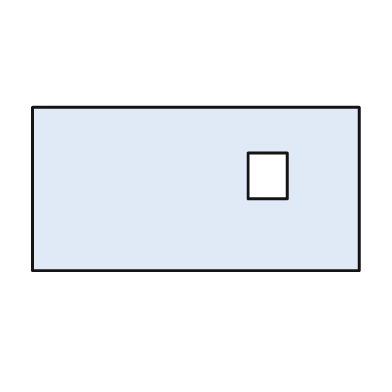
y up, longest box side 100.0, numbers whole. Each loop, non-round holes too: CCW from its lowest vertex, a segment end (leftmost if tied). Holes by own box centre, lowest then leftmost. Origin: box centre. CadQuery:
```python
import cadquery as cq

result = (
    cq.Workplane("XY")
    .moveTo(-50.0, -25.0)
    .lineTo(50.0, -25.0)
    .lineTo(50.0, 25.0)
    .lineTo(-50.0, 25.0)
    .close()
    .moveTo(16.0, -3.0)
    .lineTo(28.0, -3.0)
    .lineTo(28.0, 11.0)
    .lineTo(16.0, 11.0)
    .close()
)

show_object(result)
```